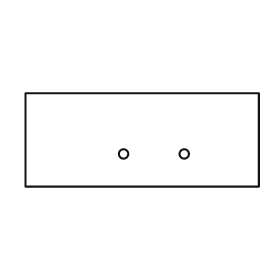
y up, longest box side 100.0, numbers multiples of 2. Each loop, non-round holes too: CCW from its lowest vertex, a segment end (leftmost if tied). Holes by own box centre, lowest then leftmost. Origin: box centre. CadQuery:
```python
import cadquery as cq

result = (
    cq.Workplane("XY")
    .moveTo(-50.0, -20.0)
    .lineTo(50.0, -20.0)
    .lineTo(50.0, 20.0)
    .lineTo(-50.0, 20.0)
    .close()
    .moveTo(-8.0, -6.0)
    .circle(2.0)
    .moveTo(18.0, -6.0)
    .circle(2.0)
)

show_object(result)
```